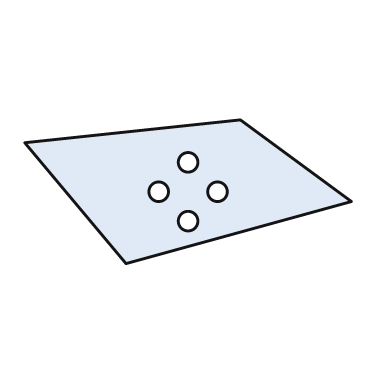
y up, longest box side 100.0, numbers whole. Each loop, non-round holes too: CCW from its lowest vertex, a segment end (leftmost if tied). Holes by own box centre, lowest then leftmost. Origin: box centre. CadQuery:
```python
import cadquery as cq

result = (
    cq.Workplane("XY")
    .moveTo(-19.0, -22.0)
    .lineTo(50.0, -3.0)
    .lineTo(16.0, 22.0)
    .lineTo(-50.0, 15.0)
    .close()
    .moveTo(0.0, -9.0)
    .circle(3.0)
    .moveTo(-9.0, 0.0)
    .circle(3.0)
    .moveTo(9.0, 0.0)
    .circle(3.0)
    .moveTo(0.0, 9.0)
    .circle(3.0)
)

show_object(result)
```